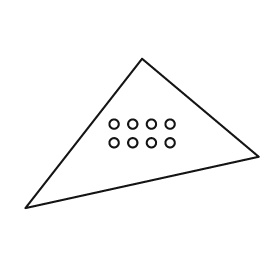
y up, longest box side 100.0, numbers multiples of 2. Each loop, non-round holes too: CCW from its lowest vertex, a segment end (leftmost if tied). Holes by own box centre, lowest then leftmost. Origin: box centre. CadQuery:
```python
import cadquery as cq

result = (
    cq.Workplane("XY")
    .moveTo(-50.0, -32.0)
    .lineTo(50.0, -10.0)
    .lineTo(0.0, 32.0)
    .close()
    .moveTo(-12.0, -4.0)
    .circle(2.0)
    .moveTo(-4.0, -4.0)
    .circle(2.0)
    .moveTo(4.0, -4.0)
    .circle(2.0)
    .moveTo(12.0, -4.0)
    .circle(2.0)
    .moveTo(-12.0, 4.0)
    .circle(2.0)
    .moveTo(-4.0, 4.0)
    .circle(2.0)
    .moveTo(4.0, 4.0)
    .circle(2.0)
    .moveTo(12.0, 4.0)
    .circle(2.0)
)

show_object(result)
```